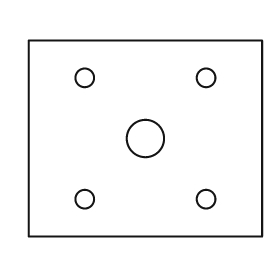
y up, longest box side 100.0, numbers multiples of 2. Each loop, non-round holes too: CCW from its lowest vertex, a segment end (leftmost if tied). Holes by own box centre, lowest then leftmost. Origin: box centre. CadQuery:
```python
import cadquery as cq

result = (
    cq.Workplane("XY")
    .moveTo(-50.0, -42.0)
    .lineTo(50.0, -42.0)
    .lineTo(50.0, 42.0)
    .lineTo(-50.0, 42.0)
    .close()
    .moveTo(-26.0, -26.0)
    .circle(4.0)
    .moveTo(26.0, -26.0)
    .circle(4.0)
    .moveTo(0.0, 0.0)
    .circle(8.0)
    .moveTo(-26.0, 26.0)
    .circle(4.0)
    .moveTo(26.0, 26.0)
    .circle(4.0)
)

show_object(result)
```